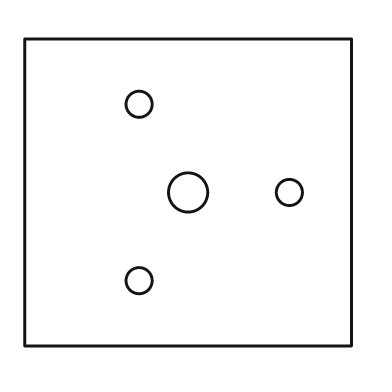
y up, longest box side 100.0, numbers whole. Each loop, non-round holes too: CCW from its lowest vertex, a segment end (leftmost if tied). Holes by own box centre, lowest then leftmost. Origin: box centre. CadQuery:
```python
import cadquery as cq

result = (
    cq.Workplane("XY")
    .moveTo(-50.0, -47.0)
    .lineTo(50.0, -47.0)
    .lineTo(50.0, 47.0)
    .lineTo(-50.0, 47.0)
    .close()
    .moveTo(-15.0, -27.0)
    .circle(4.0)
    .moveTo(0.0, 0.0)
    .circle(6.0)
    .moveTo(31.0, 0.0)
    .circle(4.0)
    .moveTo(-15.0, 27.0)
    .circle(4.0)
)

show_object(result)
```